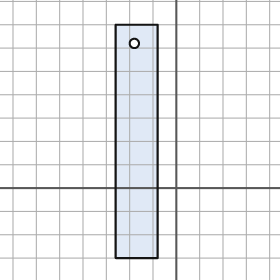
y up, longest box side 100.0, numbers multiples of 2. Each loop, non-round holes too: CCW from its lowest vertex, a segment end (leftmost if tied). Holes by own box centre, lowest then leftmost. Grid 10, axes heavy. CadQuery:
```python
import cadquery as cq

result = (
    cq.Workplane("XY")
    .moveTo(-26.0, -30.0)
    .lineTo(-8.0, -30.0)
    .lineTo(-8.0, 70.0)
    .lineTo(-26.0, 70.0)
    .close()
    .moveTo(-18.0, 62.0)
    .circle(2.0)
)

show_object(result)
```